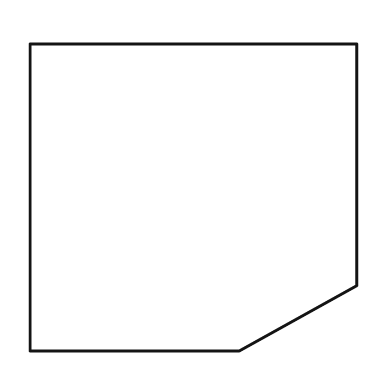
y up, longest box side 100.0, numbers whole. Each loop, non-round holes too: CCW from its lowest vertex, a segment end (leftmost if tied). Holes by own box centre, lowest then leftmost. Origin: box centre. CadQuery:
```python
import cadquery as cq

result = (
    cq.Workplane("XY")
    .moveTo(-50.0, -47.0)
    .lineTo(14.0, -47.0)
    .lineTo(50.0, -27.0)
    .lineTo(50.0, 47.0)
    .lineTo(-50.0, 47.0)
    .close()
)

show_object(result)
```